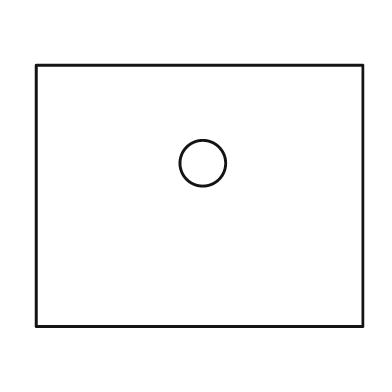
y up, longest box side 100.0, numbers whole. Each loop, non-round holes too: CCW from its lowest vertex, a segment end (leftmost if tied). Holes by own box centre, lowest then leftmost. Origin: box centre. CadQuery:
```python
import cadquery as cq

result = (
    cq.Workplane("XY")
    .moveTo(-50.0, -40.0)
    .lineTo(50.0, -40.0)
    .lineTo(50.0, 40.0)
    .lineTo(-50.0, 40.0)
    .close()
    .moveTo(1.0, 10.0)
    .circle(7.0)
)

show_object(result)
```